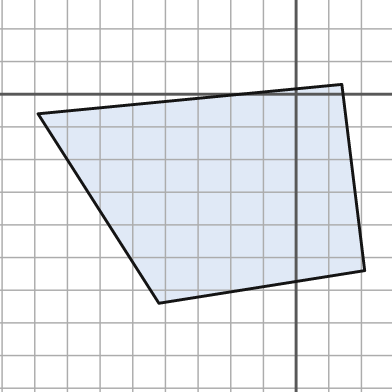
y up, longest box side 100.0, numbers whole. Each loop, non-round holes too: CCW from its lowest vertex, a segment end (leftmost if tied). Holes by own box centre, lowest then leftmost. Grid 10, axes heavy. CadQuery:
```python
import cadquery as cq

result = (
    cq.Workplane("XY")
    .moveTo(-42.0, -64.0)
    .lineTo(21.0, -54.0)
    .lineTo(14.0, 3.0)
    .lineTo(-79.0, -6.0)
    .close()
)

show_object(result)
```